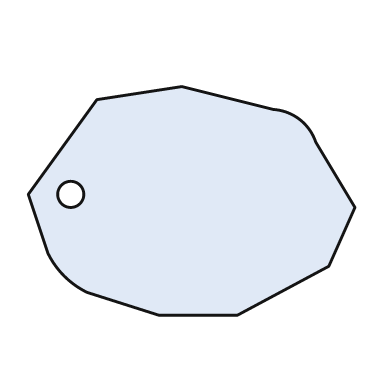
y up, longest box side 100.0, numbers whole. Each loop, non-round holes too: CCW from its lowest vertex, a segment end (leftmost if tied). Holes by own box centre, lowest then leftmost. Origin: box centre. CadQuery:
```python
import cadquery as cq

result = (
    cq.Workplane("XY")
    .moveTo(-10.0, -35.0)
    .lineTo(14.0, -35.0)
    .lineTo(42.0, -20.0)
    .lineTo(50.0, -2.0)
    .lineTo(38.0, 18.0)
    .threePointArc((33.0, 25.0), (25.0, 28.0))
    .lineTo(-3.0, 35.0)
    .lineTo(-29.0, 31.0)
    .lineTo(-50.0, 2.0)
    .lineTo(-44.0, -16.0)
    .threePointArc((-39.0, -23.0), (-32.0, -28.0))
    .close()
    .moveTo(-37.0, 2.0)
    .circle(4.0)
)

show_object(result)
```